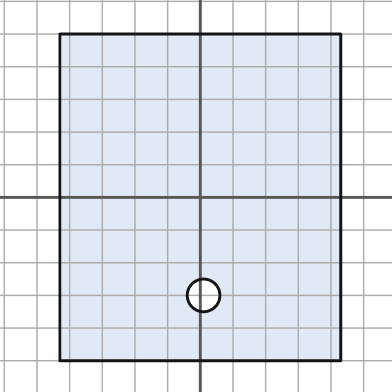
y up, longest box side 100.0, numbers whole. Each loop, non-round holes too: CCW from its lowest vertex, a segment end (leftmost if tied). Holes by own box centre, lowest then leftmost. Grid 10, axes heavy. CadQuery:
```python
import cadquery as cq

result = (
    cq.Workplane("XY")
    .moveTo(-43.0, -50.0)
    .lineTo(43.0, -50.0)
    .lineTo(43.0, 50.0)
    .lineTo(-43.0, 50.0)
    .close()
    .moveTo(1.0, -30.0)
    .circle(5.0)
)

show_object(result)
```